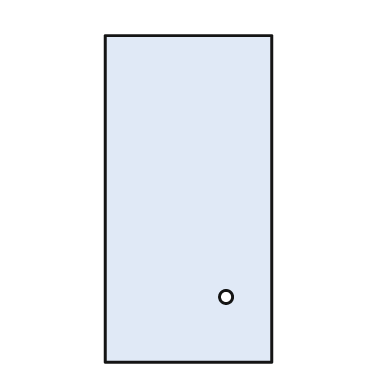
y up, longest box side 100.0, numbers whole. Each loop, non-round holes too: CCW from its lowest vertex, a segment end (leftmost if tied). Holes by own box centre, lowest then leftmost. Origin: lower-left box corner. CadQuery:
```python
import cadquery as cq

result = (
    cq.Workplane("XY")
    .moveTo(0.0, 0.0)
    .lineTo(51.0, 0.0)
    .lineTo(51.0, 100.0)
    .lineTo(0.0, 100.0)
    .close()
    .moveTo(37.0, 20.0)
    .circle(2.0)
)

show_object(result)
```